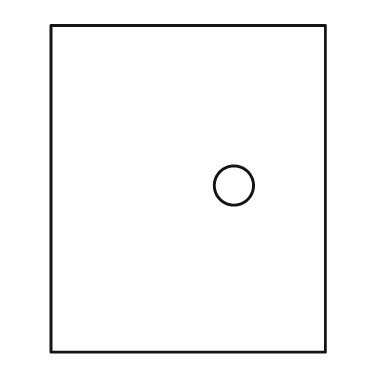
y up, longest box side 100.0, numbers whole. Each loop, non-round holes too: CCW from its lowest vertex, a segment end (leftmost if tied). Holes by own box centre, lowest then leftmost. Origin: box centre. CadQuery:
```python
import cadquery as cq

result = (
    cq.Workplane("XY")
    .moveTo(-42.0, -50.0)
    .lineTo(42.0, -50.0)
    .lineTo(42.0, 50.0)
    .lineTo(-42.0, 50.0)
    .close()
    .moveTo(14.0, 1.0)
    .circle(6.0)
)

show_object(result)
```